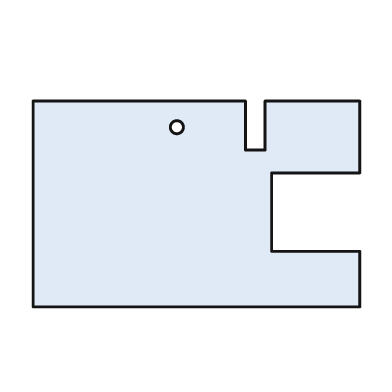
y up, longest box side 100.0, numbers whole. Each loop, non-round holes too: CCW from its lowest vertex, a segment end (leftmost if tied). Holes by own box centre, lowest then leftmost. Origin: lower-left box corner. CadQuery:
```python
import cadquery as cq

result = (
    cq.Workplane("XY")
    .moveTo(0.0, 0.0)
    .lineTo(100.0, 0.0)
    .lineTo(100.0, 17.0)
    .lineTo(73.0, 17.0)
    .lineTo(73.0, 41.0)
    .lineTo(100.0, 41.0)
    .lineTo(100.0, 63.0)
    .lineTo(71.0, 63.0)
    .lineTo(71.0, 48.0)
    .lineTo(65.0, 48.0)
    .lineTo(65.0, 63.0)
    .lineTo(0.0, 63.0)
    .close()
    .moveTo(44.0, 55.0)
    .circle(2.0)
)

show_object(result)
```